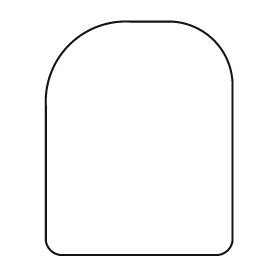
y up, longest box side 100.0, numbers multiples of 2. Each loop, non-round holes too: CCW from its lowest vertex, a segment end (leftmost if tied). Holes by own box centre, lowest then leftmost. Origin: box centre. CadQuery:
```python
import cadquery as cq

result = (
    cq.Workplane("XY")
    .moveTo(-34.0, -50.0)
    .lineTo(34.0, -50.0)
    .threePointArc((38.0, -48.0), (40.0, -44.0))
    .lineTo(40.0, 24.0)
    .threePointArc((32.0, 42.0), (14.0, 50.0))
    .lineTo(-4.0, 50.0)
    .threePointArc((-30.0, 40.0), (-40.0, 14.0))
    .lineTo(-40.0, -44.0)
    .threePointArc((-38.0, -48.0), (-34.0, -50.0))
    .close()
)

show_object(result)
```